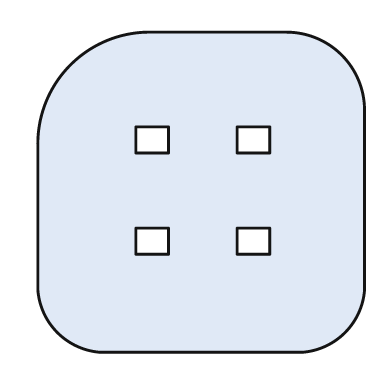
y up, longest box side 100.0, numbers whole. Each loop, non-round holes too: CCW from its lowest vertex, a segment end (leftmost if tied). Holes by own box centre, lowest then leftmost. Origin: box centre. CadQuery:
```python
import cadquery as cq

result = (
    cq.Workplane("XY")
    .moveTo(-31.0, -49.0)
    .lineTo(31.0, -49.0)
    .threePointArc((44.0, -43.0), (50.0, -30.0))
    .lineTo(50.0, 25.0)
    .threePointArc((43.0, 42.0), (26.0, 49.0))
    .lineTo(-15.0, 49.0)
    .threePointArc((-40.0, 39.0), (-50.0, 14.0))
    .lineTo(-50.0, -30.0)
    .threePointArc((-44.0, -43.0), (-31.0, -49.0))
    .close()
    .moveTo(-20.0, -19.0)
    .lineTo(-10.0, -19.0)
    .lineTo(-10.0, -11.0)
    .lineTo(-20.0, -11.0)
    .close()
    .moveTo(11.0, -19.0)
    .lineTo(21.0, -19.0)
    .lineTo(21.0, -11.0)
    .lineTo(11.0, -11.0)
    .close()
    .moveTo(-20.0, 12.0)
    .lineTo(-10.0, 12.0)
    .lineTo(-10.0, 20.0)
    .lineTo(-20.0, 20.0)
    .close()
    .moveTo(11.0, 12.0)
    .lineTo(21.0, 12.0)
    .lineTo(21.0, 20.0)
    .lineTo(11.0, 20.0)
    .close()
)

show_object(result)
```